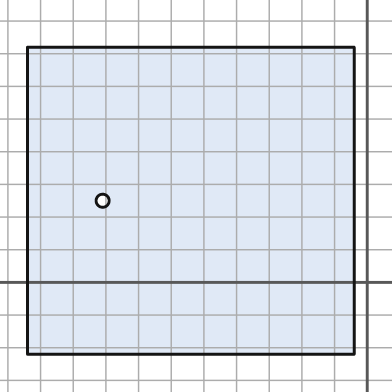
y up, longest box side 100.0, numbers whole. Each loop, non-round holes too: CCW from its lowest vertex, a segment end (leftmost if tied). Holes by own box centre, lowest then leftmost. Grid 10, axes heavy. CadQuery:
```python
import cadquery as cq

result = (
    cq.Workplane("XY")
    .moveTo(-104.0, -22.0)
    .lineTo(-4.0, -22.0)
    .lineTo(-4.0, 72.0)
    .lineTo(-104.0, 72.0)
    .close()
    .moveTo(-81.0, 25.0)
    .circle(2.0)
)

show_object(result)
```